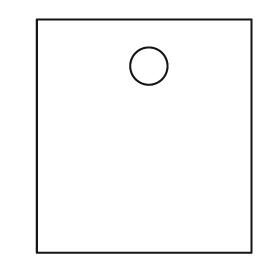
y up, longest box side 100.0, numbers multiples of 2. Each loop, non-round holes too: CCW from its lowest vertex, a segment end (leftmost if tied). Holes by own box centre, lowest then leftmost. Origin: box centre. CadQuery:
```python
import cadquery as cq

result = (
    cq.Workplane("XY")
    .moveTo(-46.0, -50.0)
    .lineTo(46.0, -50.0)
    .lineTo(46.0, 50.0)
    .lineTo(-46.0, 50.0)
    .close()
    .moveTo(2.0, 30.0)
    .circle(8.0)
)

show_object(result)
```